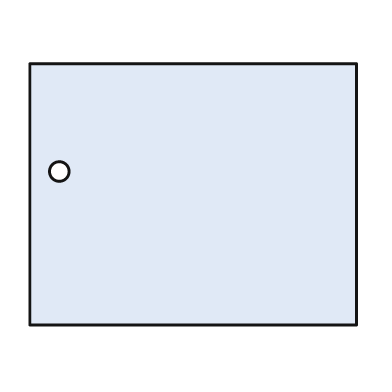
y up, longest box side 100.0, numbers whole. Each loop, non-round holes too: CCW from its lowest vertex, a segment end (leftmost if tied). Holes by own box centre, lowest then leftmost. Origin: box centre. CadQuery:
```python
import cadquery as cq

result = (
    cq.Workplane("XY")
    .moveTo(-50.0, -40.0)
    .lineTo(50.0, -40.0)
    .lineTo(50.0, 40.0)
    .lineTo(-50.0, 40.0)
    .close()
    .moveTo(-41.0, 7.0)
    .circle(3.0)
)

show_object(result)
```